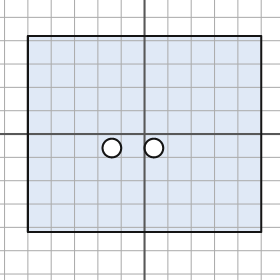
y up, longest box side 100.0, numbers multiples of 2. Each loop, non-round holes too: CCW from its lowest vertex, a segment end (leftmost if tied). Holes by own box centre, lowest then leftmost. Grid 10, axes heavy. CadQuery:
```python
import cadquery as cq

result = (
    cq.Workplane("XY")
    .moveTo(-50.0, -42.0)
    .lineTo(50.0, -42.0)
    .lineTo(50.0, 42.0)
    .lineTo(-50.0, 42.0)
    .close()
    .moveTo(-14.0, -6.0)
    .circle(4.0)
    .moveTo(4.0, -6.0)
    .circle(4.0)
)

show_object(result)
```